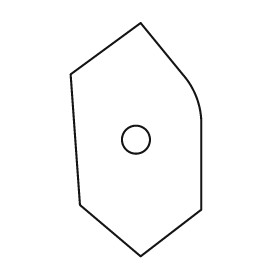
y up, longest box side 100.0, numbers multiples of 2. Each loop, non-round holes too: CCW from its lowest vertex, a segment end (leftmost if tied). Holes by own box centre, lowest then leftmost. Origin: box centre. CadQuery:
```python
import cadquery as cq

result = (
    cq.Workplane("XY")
    .moveTo(2.0, -50.0)
    .lineTo(28.0, -30.0)
    .lineTo(28.0, 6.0)
    .threePointArc((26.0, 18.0), (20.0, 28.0))
    .lineTo(2.0, 50.0)
    .lineTo(-28.0, 28.0)
    .lineTo(-24.0, -28.0)
    .close()
    .moveTo(0.0, 0.0)
    .circle(6.0)
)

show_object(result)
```